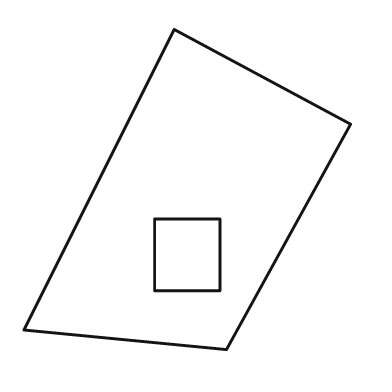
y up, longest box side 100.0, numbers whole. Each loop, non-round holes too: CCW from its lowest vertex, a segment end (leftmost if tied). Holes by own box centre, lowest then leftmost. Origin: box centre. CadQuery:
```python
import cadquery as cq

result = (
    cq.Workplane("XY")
    .moveTo(12.0, -49.0)
    .lineTo(50.0, 20.0)
    .lineTo(-4.0, 49.0)
    .lineTo(-50.0, -43.0)
    .close()
    .moveTo(-10.0, -31.0)
    .lineTo(10.0, -31.0)
    .lineTo(10.0, -9.0)
    .lineTo(-10.0, -9.0)
    .close()
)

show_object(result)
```